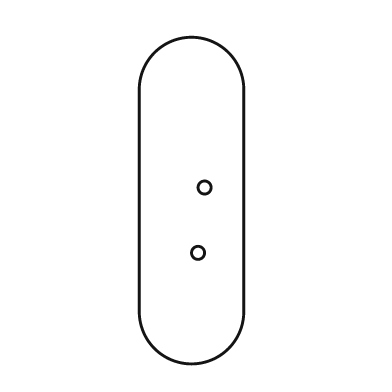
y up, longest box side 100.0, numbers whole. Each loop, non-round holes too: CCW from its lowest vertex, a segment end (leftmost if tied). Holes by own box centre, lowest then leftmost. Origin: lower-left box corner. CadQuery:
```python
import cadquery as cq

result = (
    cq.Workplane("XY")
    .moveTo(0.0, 16.0)
    .threePointArc((16.0, 0.0), (32.0, 16.0))
    .lineTo(32.0, 84.0)
    .threePointArc((16.0, 100.0), (0.0, 84.0))
    .close()
    .moveTo(18.0, 34.0)
    .circle(2.0)
    .moveTo(20.0, 54.0)
    .circle(2.0)
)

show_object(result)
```